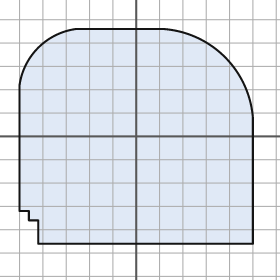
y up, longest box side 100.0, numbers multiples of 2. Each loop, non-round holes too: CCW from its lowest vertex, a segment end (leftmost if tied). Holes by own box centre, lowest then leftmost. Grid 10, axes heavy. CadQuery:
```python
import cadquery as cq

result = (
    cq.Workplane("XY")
    .moveTo(-42.0, -46.0)
    .lineTo(50.0, -46.0)
    .lineTo(50.0, 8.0)
    .threePointArc((38.0, 34.0), (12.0, 46.0))
    .lineTo(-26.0, 46.0)
    .threePointArc((-42.0, 38.0), (-50.0, 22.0))
    .lineTo(-50.0, -32.0)
    .lineTo(-46.0, -32.0)
    .lineTo(-46.0, -36.0)
    .lineTo(-42.0, -36.0)
    .close()
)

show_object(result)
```